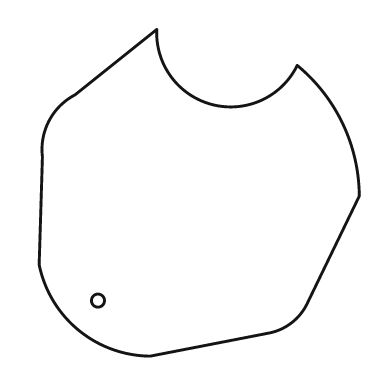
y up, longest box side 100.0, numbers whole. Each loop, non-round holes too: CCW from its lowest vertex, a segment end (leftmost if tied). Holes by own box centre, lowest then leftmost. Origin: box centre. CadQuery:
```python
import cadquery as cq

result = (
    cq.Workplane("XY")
    .moveTo(-15.0, -50.0)
    .lineTo(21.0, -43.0)
    .threePointArc((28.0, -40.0), (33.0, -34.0))
    .lineTo(49.0, -1.0)
    .threePointArc((44.0, 21.0), (30.0, 39.0))
    .threePointArc((4.0, 27.0), (-13.0, 50.0))
    .lineTo(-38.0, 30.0)
    .threePointArc((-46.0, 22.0), (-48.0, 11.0))
    .lineTo(-49.0, -22.0)
    .threePointArc((-37.0, -42.0), (-15.0, -50.0))
    .close()
    .moveTo(-31.0, -33.0)
    .circle(2.0)
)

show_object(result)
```